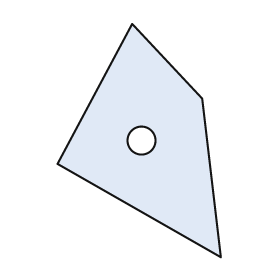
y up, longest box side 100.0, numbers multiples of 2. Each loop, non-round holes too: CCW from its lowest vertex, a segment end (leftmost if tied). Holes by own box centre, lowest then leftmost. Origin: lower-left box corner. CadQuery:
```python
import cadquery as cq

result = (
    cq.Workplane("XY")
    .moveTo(70.0, 0.0)
    .lineTo(62.0, 68.0)
    .lineTo(32.0, 100.0)
    .lineTo(0.0, 40.0)
    .close()
    .moveTo(36.0, 50.0)
    .circle(6.0)
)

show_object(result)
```